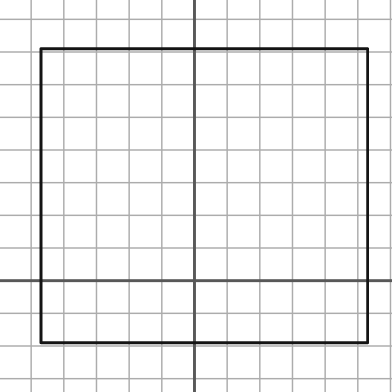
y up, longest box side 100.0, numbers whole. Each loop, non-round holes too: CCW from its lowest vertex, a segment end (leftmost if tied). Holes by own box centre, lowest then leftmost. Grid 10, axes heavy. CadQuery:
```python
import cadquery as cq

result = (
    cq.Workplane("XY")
    .moveTo(-47.0, -19.0)
    .lineTo(53.0, -19.0)
    .lineTo(53.0, 71.0)
    .lineTo(-47.0, 71.0)
    .close()
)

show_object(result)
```